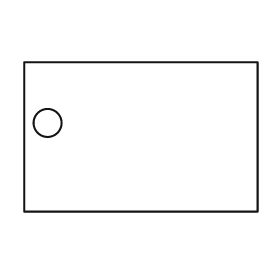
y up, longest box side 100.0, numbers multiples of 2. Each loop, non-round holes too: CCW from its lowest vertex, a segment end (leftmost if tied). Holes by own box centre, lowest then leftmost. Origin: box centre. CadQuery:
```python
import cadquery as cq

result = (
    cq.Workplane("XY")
    .moveTo(-50.0, -32.0)
    .lineTo(50.0, -32.0)
    .lineTo(50.0, 32.0)
    .lineTo(-50.0, 32.0)
    .close()
    .moveTo(-40.0, 6.0)
    .circle(6.0)
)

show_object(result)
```